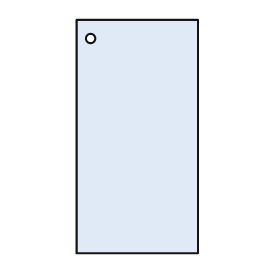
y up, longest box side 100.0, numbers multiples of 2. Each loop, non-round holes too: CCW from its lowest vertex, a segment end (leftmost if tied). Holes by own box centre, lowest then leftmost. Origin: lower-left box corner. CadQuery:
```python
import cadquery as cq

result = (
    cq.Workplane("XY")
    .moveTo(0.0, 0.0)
    .lineTo(52.0, 0.0)
    .lineTo(52.0, 100.0)
    .lineTo(0.0, 100.0)
    .close()
    .moveTo(6.0, 92.0)
    .circle(2.0)
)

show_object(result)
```